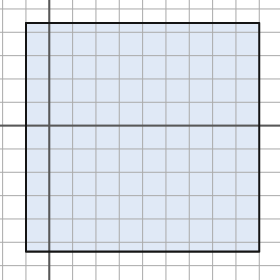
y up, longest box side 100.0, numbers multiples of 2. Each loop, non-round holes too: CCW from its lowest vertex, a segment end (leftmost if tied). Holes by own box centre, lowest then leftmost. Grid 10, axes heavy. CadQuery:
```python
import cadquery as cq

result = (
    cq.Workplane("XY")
    .moveTo(-10.0, -54.0)
    .lineTo(90.0, -54.0)
    .lineTo(90.0, 44.0)
    .lineTo(-10.0, 44.0)
    .close()
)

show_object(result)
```